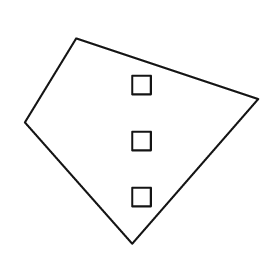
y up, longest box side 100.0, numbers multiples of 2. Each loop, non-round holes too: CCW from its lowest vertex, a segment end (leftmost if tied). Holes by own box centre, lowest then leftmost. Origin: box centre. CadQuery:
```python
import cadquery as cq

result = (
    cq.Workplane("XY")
    .moveTo(-4.0, -44.0)
    .lineTo(50.0, 18.0)
    .lineTo(-28.0, 44.0)
    .lineTo(-50.0, 8.0)
    .close()
    .moveTo(-4.0, -28.0)
    .lineTo(4.0, -28.0)
    .lineTo(4.0, -20.0)
    .lineTo(-4.0, -20.0)
    .close()
    .moveTo(-4.0, -4.0)
    .lineTo(4.0, -4.0)
    .lineTo(4.0, 4.0)
    .lineTo(-4.0, 4.0)
    .close()
    .moveTo(-4.0, 20.0)
    .lineTo(4.0, 20.0)
    .lineTo(4.0, 28.0)
    .lineTo(-4.0, 28.0)
    .close()
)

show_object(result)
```